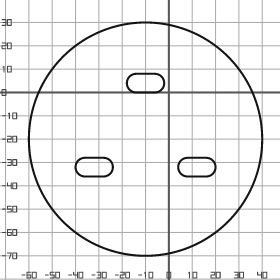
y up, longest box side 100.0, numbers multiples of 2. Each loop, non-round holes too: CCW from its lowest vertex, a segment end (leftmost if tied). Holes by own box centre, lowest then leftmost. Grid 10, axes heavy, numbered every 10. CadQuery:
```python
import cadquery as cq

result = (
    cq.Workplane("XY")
    .moveTo(-10.0, -20.0)
    .circle(50.0)
    .moveTo(-36.0, -36.0)
    .lineTo(-28.0, -36.0)
    .threePointArc((-24.0, -32.0), (-28.0, -28.0))
    .lineTo(-36.0, -28.0)
    .threePointArc((-40.0, -32.0), (-36.0, -36.0))
    .close()
    .moveTo(8.0, -36.0)
    .lineTo(16.0, -36.0)
    .threePointArc((20.0, -32.0), (16.0, -28.0))
    .lineTo(8.0, -28.0)
    .threePointArc((4.0, -32.0), (8.0, -36.0))
    .close()
    .moveTo(-14.0, 0.0)
    .lineTo(-6.0, 0.0)
    .threePointArc((-2.0, 4.0), (-6.0, 8.0))
    .lineTo(-14.0, 8.0)
    .threePointArc((-18.0, 4.0), (-14.0, 0.0))
    .close()
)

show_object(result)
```